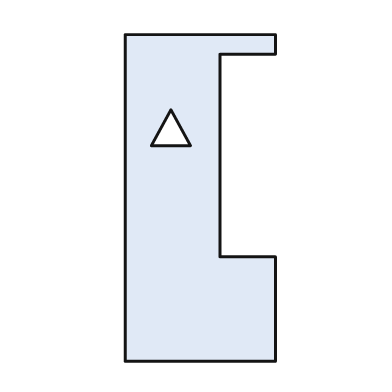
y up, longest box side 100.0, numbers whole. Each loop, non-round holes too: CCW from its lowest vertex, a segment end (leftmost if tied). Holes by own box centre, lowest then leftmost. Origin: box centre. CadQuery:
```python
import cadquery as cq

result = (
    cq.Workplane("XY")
    .moveTo(-23.0, -50.0)
    .lineTo(23.0, -50.0)
    .lineTo(23.0, -18.0)
    .lineTo(6.0, -18.0)
    .lineTo(6.0, 44.0)
    .lineTo(23.0, 44.0)
    .lineTo(23.0, 50.0)
    .lineTo(-23.0, 50.0)
    .close()
    .moveTo(-15.0, 16.0)
    .lineTo(-3.0, 16.0)
    .lineTo(-9.0, 27.0)
    .close()
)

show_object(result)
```